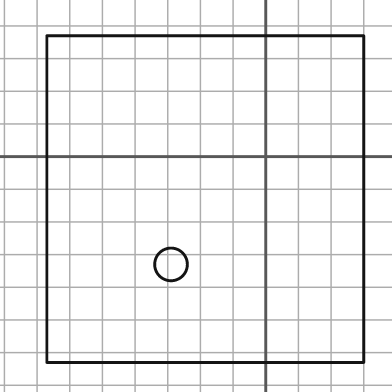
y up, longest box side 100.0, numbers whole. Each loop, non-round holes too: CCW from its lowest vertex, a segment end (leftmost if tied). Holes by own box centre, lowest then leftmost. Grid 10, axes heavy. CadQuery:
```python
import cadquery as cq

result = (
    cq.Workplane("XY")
    .moveTo(-67.0, -63.0)
    .lineTo(30.0, -63.0)
    .lineTo(30.0, 37.0)
    .lineTo(-67.0, 37.0)
    .close()
    .moveTo(-29.0, -33.0)
    .circle(5.0)
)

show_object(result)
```